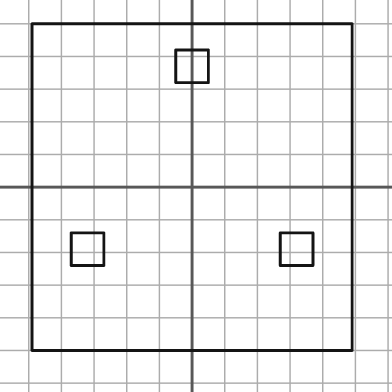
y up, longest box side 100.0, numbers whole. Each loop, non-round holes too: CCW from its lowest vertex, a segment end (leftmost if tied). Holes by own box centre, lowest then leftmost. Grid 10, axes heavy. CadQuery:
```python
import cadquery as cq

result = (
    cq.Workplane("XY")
    .moveTo(-49.0, -50.0)
    .lineTo(49.0, -50.0)
    .lineTo(49.0, 50.0)
    .lineTo(-49.0, 50.0)
    .close()
    .moveTo(-37.0, -24.0)
    .lineTo(-27.0, -24.0)
    .lineTo(-27.0, -14.0)
    .lineTo(-37.0, -14.0)
    .close()
    .moveTo(27.0, -24.0)
    .lineTo(37.0, -24.0)
    .lineTo(37.0, -14.0)
    .lineTo(27.0, -14.0)
    .close()
    .moveTo(-5.0, 32.0)
    .lineTo(5.0, 32.0)
    .lineTo(5.0, 42.0)
    .lineTo(-5.0, 42.0)
    .close()
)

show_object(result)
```